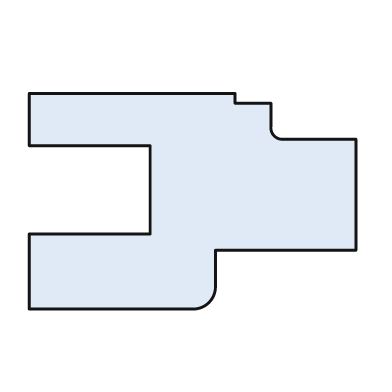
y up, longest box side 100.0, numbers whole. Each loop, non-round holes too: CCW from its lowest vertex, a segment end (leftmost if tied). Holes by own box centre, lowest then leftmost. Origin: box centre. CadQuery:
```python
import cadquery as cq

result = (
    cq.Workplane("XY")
    .moveTo(-50.0, -33.0)
    .lineTo(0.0, -33.0)
    .threePointArc((5.0, -31.0), (7.0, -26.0))
    .lineTo(7.0, -15.0)
    .lineTo(50.0, -15.0)
    .lineTo(50.0, 19.0)
    .lineTo(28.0, 19.0)
    .threePointArc((25.0, 20.0), (24.0, 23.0))
    .lineTo(24.0, 30.0)
    .lineTo(13.0, 30.0)
    .lineTo(13.0, 33.0)
    .lineTo(-50.0, 33.0)
    .lineTo(-50.0, 17.0)
    .lineTo(-13.0, 17.0)
    .lineTo(-13.0, -10.0)
    .lineTo(-50.0, -10.0)
    .close()
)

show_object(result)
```